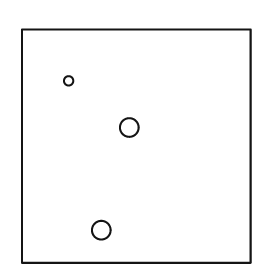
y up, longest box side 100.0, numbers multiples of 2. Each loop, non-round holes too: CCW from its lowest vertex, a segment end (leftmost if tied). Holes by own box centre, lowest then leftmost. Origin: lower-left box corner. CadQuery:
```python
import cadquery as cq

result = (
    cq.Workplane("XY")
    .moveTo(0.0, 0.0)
    .lineTo(98.0, 0.0)
    .lineTo(98.0, 100.0)
    .lineTo(0.0, 100.0)
    .close()
    .moveTo(34.0, 14.0)
    .circle(4.0)
    .moveTo(46.0, 58.0)
    .circle(4.0)
    .moveTo(20.0, 78.0)
    .circle(2.0)
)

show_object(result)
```